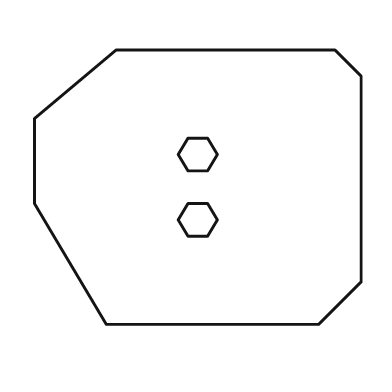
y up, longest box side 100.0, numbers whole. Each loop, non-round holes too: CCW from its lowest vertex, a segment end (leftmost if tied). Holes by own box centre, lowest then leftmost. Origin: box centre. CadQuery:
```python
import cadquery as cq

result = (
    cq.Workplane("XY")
    .moveTo(-28.0, -42.0)
    .lineTo(37.0, -42.0)
    .lineTo(50.0, -29.0)
    .lineTo(50.0, 34.0)
    .lineTo(42.0, 42.0)
    .lineTo(-25.0, 42.0)
    .lineTo(-50.0, 21.0)
    .lineTo(-50.0, -5.0)
    .close()
    .moveTo(-3.0, -15.0)
    .lineTo(3.0, -15.0)
    .lineTo(6.0, -10.0)
    .lineTo(3.0, -5.0)
    .lineTo(-3.0, -5.0)
    .lineTo(-6.0, -10.0)
    .close()
    .moveTo(-3.0, 5.0)
    .lineTo(3.0, 5.0)
    .lineTo(6.0, 10.0)
    .lineTo(3.0, 15.0)
    .lineTo(-3.0, 15.0)
    .lineTo(-6.0, 10.0)
    .close()
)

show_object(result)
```